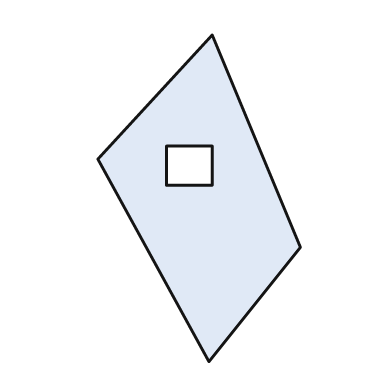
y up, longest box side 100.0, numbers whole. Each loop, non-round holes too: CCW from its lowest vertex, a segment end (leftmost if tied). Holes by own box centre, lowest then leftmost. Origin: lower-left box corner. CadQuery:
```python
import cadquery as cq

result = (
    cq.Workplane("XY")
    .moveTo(34.0, 0.0)
    .lineTo(62.0, 35.0)
    .lineTo(35.0, 100.0)
    .lineTo(0.0, 62.0)
    .close()
    .moveTo(21.0, 54.0)
    .lineTo(35.0, 54.0)
    .lineTo(35.0, 66.0)
    .lineTo(21.0, 66.0)
    .close()
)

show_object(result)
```